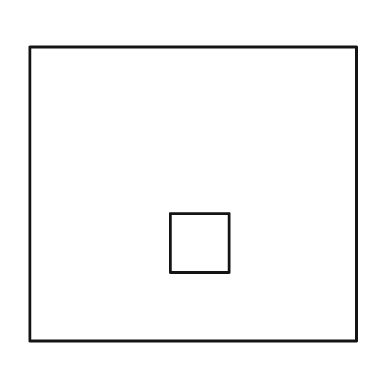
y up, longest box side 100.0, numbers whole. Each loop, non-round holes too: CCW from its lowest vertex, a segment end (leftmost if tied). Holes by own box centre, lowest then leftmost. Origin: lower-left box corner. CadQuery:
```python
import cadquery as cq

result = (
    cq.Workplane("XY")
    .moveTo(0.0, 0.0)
    .lineTo(100.0, 0.0)
    .lineTo(100.0, 90.0)
    .lineTo(0.0, 90.0)
    .close()
    .moveTo(43.0, 21.0)
    .lineTo(61.0, 21.0)
    .lineTo(61.0, 39.0)
    .lineTo(43.0, 39.0)
    .close()
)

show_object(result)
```